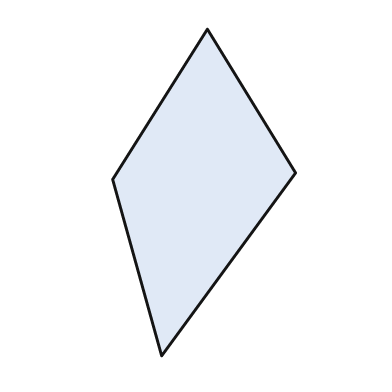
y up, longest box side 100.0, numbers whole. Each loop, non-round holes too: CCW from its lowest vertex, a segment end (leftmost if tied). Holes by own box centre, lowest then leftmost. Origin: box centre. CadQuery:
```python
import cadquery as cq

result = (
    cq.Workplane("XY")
    .moveTo(-13.0, -50.0)
    .lineTo(28.0, 6.0)
    .lineTo(1.0, 50.0)
    .lineTo(-28.0, 4.0)
    .close()
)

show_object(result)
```